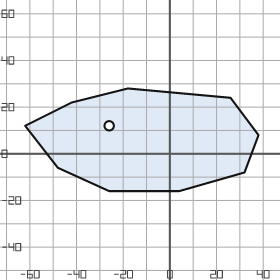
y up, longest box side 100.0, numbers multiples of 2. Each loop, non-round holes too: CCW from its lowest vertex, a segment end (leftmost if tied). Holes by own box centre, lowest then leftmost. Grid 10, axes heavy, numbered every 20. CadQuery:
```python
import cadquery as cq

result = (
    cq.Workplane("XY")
    .moveTo(-26.0, -16.0)
    .lineTo(4.0, -16.0)
    .lineTo(32.0, -8.0)
    .lineTo(38.0, 8.0)
    .lineTo(26.0, 24.0)
    .lineTo(-18.0, 28.0)
    .lineTo(-42.0, 22.0)
    .lineTo(-62.0, 12.0)
    .lineTo(-48.0, -6.0)
    .close()
    .moveTo(-26.0, 12.0)
    .circle(2.0)
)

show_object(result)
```